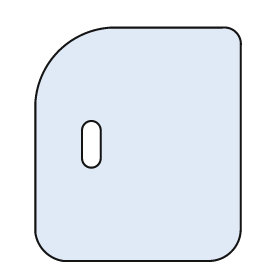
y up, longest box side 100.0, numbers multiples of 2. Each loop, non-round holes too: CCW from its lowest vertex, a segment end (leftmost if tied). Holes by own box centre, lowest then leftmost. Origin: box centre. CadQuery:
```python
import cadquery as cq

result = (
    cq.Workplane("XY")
    .moveTo(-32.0, -50.0)
    .lineTo(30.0, -50.0)
    .threePointArc((40.0, -46.0), (44.0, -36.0))
    .lineTo(44.0, 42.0)
    .threePointArc((42.0, 48.0), (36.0, 50.0))
    .lineTo(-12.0, 50.0)
    .threePointArc((-34.0, 40.0), (-44.0, 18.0))
    .lineTo(-44.0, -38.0)
    .threePointArc((-40.0, -46.0), (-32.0, -50.0))
    .close()
    .moveTo(-24.0, -6.0)
    .threePointArc((-20.0, -10.0), (-16.0, -6.0))
    .lineTo(-16.0, 6.0)
    .threePointArc((-20.0, 10.0), (-24.0, 6.0))
    .close()
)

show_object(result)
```